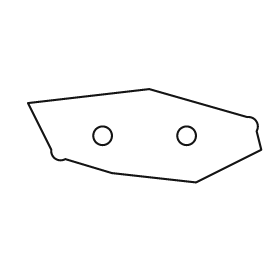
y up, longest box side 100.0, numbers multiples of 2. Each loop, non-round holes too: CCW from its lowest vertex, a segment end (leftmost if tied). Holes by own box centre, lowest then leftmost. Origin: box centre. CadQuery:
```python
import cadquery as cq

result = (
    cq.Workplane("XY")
    .moveTo(22.0, -20.0)
    .lineTo(50.0, -6.0)
    .lineTo(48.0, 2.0)
    .threePointArc((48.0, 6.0), (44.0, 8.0))
    .lineTo(2.0, 20.0)
    .lineTo(-50.0, 14.0)
    .lineTo(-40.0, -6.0)
    .threePointArc((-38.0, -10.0), (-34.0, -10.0))
    .lineTo(-14.0, -16.0)
    .close()
    .moveTo(-18.0, 0.0)
    .circle(4.0)
    .moveTo(18.0, 0.0)
    .circle(4.0)
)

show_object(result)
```